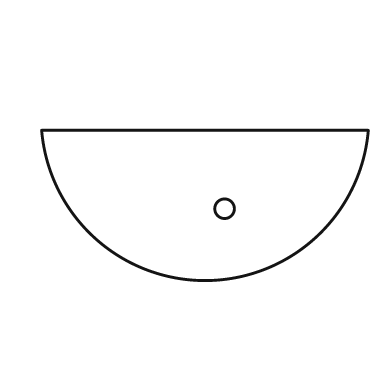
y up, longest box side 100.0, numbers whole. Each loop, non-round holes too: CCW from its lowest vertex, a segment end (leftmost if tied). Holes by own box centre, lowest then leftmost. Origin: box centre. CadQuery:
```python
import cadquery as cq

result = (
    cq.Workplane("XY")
    .moveTo(-50.0, 23.0)
    .threePointArc((0.0, -23.0), (50.0, 23.0))
    .close()
    .moveTo(6.0, -1.0)
    .circle(3.0)
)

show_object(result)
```